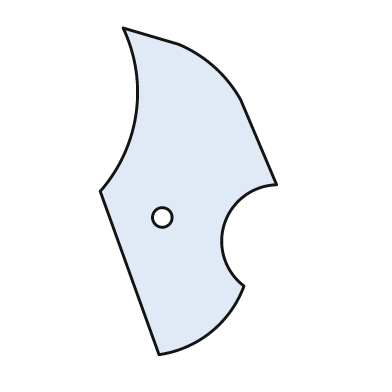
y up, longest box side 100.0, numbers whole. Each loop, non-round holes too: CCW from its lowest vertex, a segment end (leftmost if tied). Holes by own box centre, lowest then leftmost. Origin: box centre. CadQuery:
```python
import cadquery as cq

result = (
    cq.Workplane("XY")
    .moveTo(-9.0, -50.0)
    .threePointArc((7.0, -43.0), (17.0, -29.0))
    .threePointArc((11.0, -10.0), (27.0, 2.0))
    .lineTo(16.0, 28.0)
    .threePointArc((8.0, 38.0), (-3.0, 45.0))
    .lineTo(-20.0, 50.0)
    .threePointArc((-16.0, 24.0), (-27.0, 0.0))
    .close()
    .moveTo(-8.0, -8.0)
    .circle(3.0)
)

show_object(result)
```